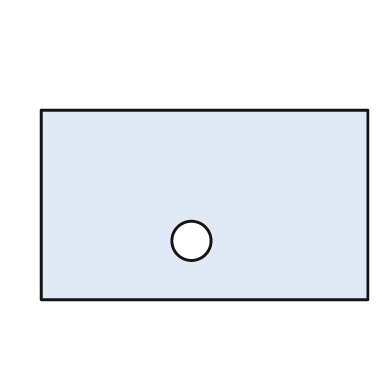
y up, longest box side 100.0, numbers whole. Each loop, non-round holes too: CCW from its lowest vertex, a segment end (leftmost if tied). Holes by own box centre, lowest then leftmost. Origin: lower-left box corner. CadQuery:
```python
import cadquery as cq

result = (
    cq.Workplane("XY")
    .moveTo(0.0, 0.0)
    .lineTo(100.0, 0.0)
    .lineTo(100.0, 58.0)
    .lineTo(0.0, 58.0)
    .close()
    .moveTo(46.0, 18.0)
    .circle(6.0)
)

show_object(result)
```